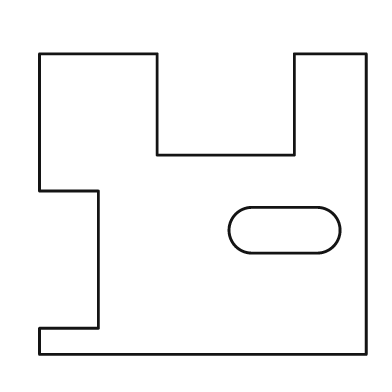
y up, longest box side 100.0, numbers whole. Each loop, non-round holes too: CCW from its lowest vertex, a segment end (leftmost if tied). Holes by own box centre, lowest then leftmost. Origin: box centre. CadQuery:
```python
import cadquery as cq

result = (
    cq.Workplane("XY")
    .moveTo(-50.0, -46.0)
    .lineTo(50.0, -46.0)
    .lineTo(50.0, 46.0)
    .lineTo(28.0, 46.0)
    .lineTo(28.0, 15.0)
    .lineTo(-14.0, 15.0)
    .lineTo(-14.0, 46.0)
    .lineTo(-50.0, 46.0)
    .lineTo(-50.0, 4.0)
    .lineTo(-32.0, 4.0)
    .lineTo(-32.0, -38.0)
    .lineTo(-50.0, -38.0)
    .close()
    .moveTo(15.0, -15.0)
    .lineTo(35.0, -15.0)
    .threePointArc((42.0, -8.0), (35.0, -1.0))
    .lineTo(15.0, -1.0)
    .threePointArc((8.0, -8.0), (15.0, -15.0))
    .close()
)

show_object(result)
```